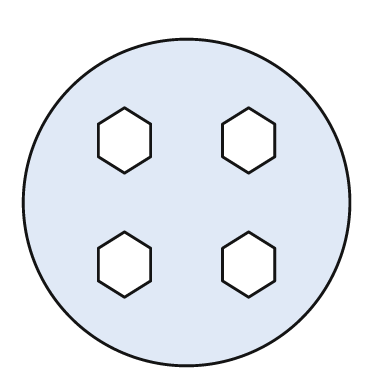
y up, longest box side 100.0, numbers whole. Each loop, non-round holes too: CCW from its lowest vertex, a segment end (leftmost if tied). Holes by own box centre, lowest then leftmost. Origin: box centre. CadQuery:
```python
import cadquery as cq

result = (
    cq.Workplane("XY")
    .moveTo(0.0, 0.0)
    .circle(50.0)
    .moveTo(-19.0, -29.0)
    .lineTo(-11.0, -24.0)
    .lineTo(-11.0, -14.0)
    .lineTo(-19.0, -9.0)
    .lineTo(-27.0, -14.0)
    .lineTo(-27.0, -24.0)
    .close()
    .moveTo(19.0, -29.0)
    .lineTo(27.0, -24.0)
    .lineTo(27.0, -14.0)
    .lineTo(19.0, -9.0)
    .lineTo(11.0, -14.0)
    .lineTo(11.0, -24.0)
    .close()
    .moveTo(-19.0, 9.0)
    .lineTo(-11.0, 14.0)
    .lineTo(-11.0, 24.0)
    .lineTo(-19.0, 29.0)
    .lineTo(-27.0, 24.0)
    .lineTo(-27.0, 14.0)
    .close()
    .moveTo(19.0, 9.0)
    .lineTo(27.0, 14.0)
    .lineTo(27.0, 24.0)
    .lineTo(19.0, 29.0)
    .lineTo(11.0, 24.0)
    .lineTo(11.0, 14.0)
    .close()
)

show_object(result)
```